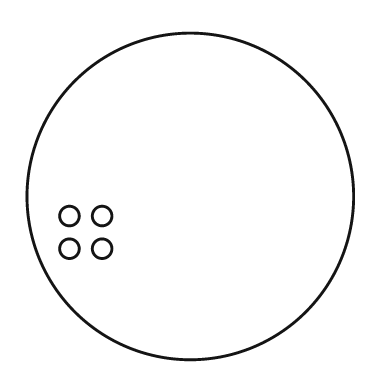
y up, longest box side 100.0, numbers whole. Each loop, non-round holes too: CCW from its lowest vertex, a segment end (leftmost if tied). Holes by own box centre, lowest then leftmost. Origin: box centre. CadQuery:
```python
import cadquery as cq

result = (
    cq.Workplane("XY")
    .moveTo(0.0, 0.0)
    .circle(50.0)
    .moveTo(-37.0, -16.0)
    .circle(3.0)
    .moveTo(-27.0, -16.0)
    .circle(3.0)
    .moveTo(-37.0, -6.0)
    .circle(3.0)
    .moveTo(-27.0, -6.0)
    .circle(3.0)
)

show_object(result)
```